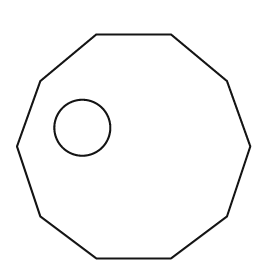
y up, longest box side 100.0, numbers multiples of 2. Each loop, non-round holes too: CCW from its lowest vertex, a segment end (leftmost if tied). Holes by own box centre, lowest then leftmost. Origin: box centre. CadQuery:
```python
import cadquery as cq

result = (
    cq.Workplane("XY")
    .moveTo(-16.0, -48.0)
    .lineTo(16.0, -48.0)
    .lineTo(40.0, -30.0)
    .lineTo(50.0, 0.0)
    .lineTo(40.0, 28.0)
    .lineTo(16.0, 48.0)
    .lineTo(-16.0, 48.0)
    .lineTo(-40.0, 28.0)
    .lineTo(-50.0, 0.0)
    .lineTo(-40.0, -30.0)
    .close()
    .moveTo(-22.0, 8.0)
    .circle(12.0)
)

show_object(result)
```